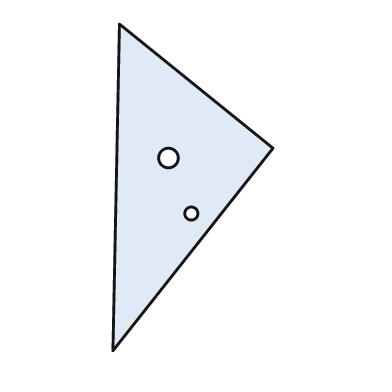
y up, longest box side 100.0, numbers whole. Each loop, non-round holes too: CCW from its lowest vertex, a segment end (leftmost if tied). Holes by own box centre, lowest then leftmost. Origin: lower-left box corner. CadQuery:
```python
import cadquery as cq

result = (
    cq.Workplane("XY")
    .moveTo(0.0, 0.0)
    .lineTo(49.0, 62.0)
    .lineTo(2.0, 100.0)
    .close()
    .moveTo(24.0, 42.0)
    .circle(2.0)
    .moveTo(17.0, 59.0)
    .circle(3.0)
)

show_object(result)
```